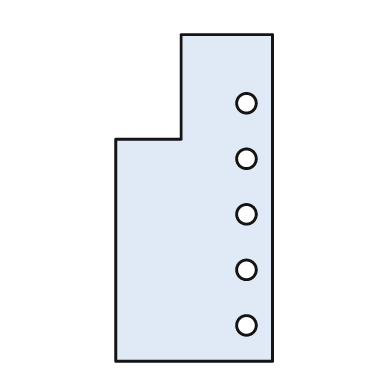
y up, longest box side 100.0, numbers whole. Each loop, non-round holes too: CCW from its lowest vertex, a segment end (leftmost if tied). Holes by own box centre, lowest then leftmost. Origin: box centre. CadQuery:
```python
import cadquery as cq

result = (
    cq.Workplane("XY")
    .moveTo(-24.0, -50.0)
    .lineTo(24.0, -50.0)
    .lineTo(24.0, 50.0)
    .lineTo(-4.0, 50.0)
    .lineTo(-4.0, 18.0)
    .lineTo(-24.0, 18.0)
    .close()
    .moveTo(16.0, -39.0)
    .circle(3.0)
    .moveTo(16.0, -22.0)
    .circle(3.0)
    .moveTo(16.0, -5.0)
    .circle(3.0)
    .moveTo(16.0, 12.0)
    .circle(3.0)
    .moveTo(16.0, 29.0)
    .circle(3.0)
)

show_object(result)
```